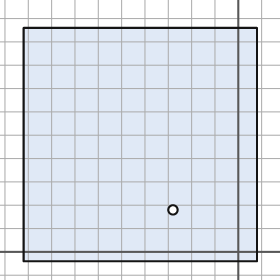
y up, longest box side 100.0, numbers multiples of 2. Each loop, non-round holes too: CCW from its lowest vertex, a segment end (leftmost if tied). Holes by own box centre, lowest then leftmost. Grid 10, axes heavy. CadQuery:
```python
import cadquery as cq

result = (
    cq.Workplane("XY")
    .moveTo(-92.0, -4.0)
    .lineTo(8.0, -4.0)
    .lineTo(8.0, 96.0)
    .lineTo(-92.0, 96.0)
    .close()
    .moveTo(-28.0, 18.0)
    .circle(2.0)
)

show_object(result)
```